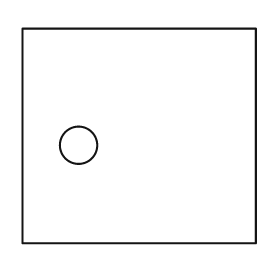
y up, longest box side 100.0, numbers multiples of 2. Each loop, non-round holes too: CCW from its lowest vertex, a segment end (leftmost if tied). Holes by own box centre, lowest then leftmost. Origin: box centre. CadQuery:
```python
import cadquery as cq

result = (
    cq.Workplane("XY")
    .moveTo(-50.0, -46.0)
    .lineTo(50.0, -46.0)
    .lineTo(50.0, 46.0)
    .lineTo(-50.0, 46.0)
    .close()
    .moveTo(-26.0, -4.0)
    .circle(8.0)
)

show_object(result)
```